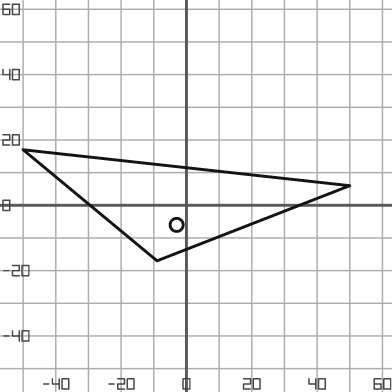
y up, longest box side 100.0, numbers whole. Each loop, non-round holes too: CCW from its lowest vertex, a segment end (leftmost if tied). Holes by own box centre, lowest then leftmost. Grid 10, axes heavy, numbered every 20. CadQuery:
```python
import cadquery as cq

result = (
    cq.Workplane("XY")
    .moveTo(-9.0, -17.0)
    .lineTo(50.0, 6.0)
    .lineTo(-50.0, 17.0)
    .close()
    .moveTo(-3.0, -6.0)
    .circle(2.0)
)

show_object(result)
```